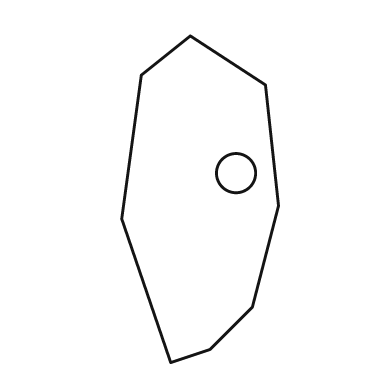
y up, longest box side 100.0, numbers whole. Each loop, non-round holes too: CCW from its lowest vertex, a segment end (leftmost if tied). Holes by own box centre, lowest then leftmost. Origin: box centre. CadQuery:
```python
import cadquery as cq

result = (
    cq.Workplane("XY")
    .moveTo(-9.0, -50.0)
    .lineTo(3.0, -46.0)
    .lineTo(16.0, -33.0)
    .lineTo(24.0, -2.0)
    .lineTo(20.0, 35.0)
    .lineTo(-3.0, 50.0)
    .lineTo(-18.0, 38.0)
    .lineTo(-24.0, -6.0)
    .close()
    .moveTo(11.0, 8.0)
    .circle(6.0)
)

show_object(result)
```